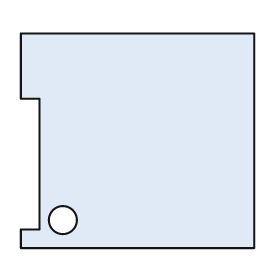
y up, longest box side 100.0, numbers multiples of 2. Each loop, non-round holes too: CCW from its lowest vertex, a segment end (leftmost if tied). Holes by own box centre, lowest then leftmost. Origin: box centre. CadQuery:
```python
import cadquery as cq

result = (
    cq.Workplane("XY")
    .moveTo(-50.0, -46.0)
    .lineTo(50.0, -46.0)
    .lineTo(50.0, 46.0)
    .lineTo(-50.0, 46.0)
    .lineTo(-50.0, 18.0)
    .lineTo(-42.0, 18.0)
    .lineTo(-42.0, -38.0)
    .lineTo(-50.0, -38.0)
    .close()
    .moveTo(-32.0, -34.0)
    .circle(6.0)
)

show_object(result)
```